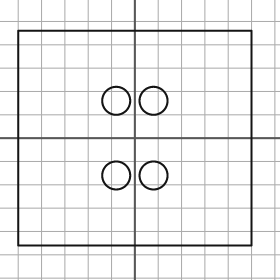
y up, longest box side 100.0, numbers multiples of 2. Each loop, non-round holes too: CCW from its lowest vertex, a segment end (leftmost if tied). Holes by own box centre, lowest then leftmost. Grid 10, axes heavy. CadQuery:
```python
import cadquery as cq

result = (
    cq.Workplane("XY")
    .moveTo(-50.0, -46.0)
    .lineTo(50.0, -46.0)
    .lineTo(50.0, 46.0)
    .lineTo(-50.0, 46.0)
    .close()
    .moveTo(-8.0, -16.0)
    .circle(6.0)
    .moveTo(8.0, -16.0)
    .circle(6.0)
    .moveTo(-8.0, 16.0)
    .circle(6.0)
    .moveTo(8.0, 16.0)
    .circle(6.0)
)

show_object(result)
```